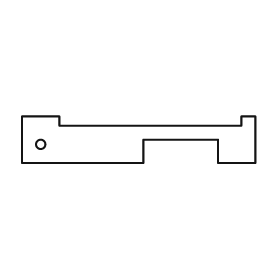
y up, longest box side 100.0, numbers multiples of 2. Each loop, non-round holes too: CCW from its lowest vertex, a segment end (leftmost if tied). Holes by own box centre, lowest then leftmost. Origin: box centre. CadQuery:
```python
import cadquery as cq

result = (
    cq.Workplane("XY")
    .moveTo(-50.0, -10.0)
    .lineTo(2.0, -10.0)
    .lineTo(2.0, 0.0)
    .lineTo(34.0, 0.0)
    .lineTo(34.0, -10.0)
    .lineTo(50.0, -10.0)
    .lineTo(50.0, 10.0)
    .lineTo(44.0, 10.0)
    .lineTo(44.0, 6.0)
    .lineTo(-34.0, 6.0)
    .lineTo(-34.0, 10.0)
    .lineTo(-50.0, 10.0)
    .close()
    .moveTo(-42.0, -2.0)
    .circle(2.0)
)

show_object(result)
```